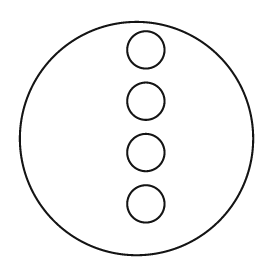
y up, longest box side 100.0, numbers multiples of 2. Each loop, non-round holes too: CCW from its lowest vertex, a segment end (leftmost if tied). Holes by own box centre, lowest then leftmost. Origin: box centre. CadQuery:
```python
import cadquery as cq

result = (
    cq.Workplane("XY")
    .moveTo(0.0, 0.0)
    .circle(50.0)
    .moveTo(4.0, -28.0)
    .circle(8.0)
    .moveTo(4.0, -6.0)
    .circle(8.0)
    .moveTo(4.0, 16.0)
    .circle(8.0)
    .moveTo(4.0, 38.0)
    .circle(8.0)
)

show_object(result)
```